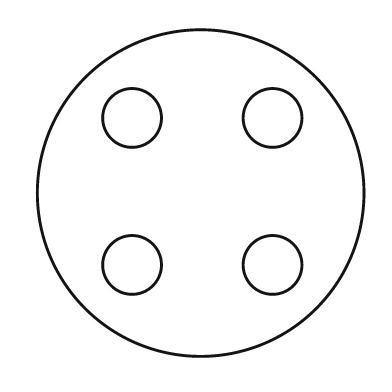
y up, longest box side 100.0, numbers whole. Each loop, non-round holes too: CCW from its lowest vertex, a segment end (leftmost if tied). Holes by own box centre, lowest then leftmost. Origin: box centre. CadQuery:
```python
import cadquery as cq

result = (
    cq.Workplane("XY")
    .moveTo(0.0, 0.0)
    .circle(50.0)
    .moveTo(-21.0, -22.0)
    .circle(9.0)
    .moveTo(22.0, -22.0)
    .circle(9.0)
    .moveTo(-21.0, 23.0)
    .circle(9.0)
    .moveTo(22.0, 23.0)
    .circle(9.0)
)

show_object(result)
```